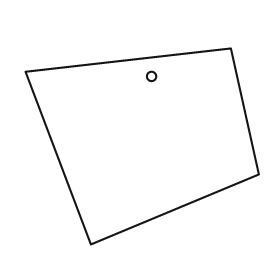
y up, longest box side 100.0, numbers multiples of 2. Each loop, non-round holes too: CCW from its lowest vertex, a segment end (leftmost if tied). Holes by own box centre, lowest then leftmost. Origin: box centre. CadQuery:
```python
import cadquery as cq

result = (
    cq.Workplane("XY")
    .moveTo(-22.0, -42.0)
    .lineTo(50.0, -12.0)
    .lineTo(38.0, 42.0)
    .lineTo(-50.0, 32.0)
    .close()
    .moveTo(4.0, 30.0)
    .circle(2.0)
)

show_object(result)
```